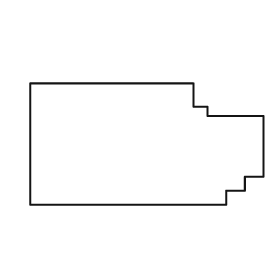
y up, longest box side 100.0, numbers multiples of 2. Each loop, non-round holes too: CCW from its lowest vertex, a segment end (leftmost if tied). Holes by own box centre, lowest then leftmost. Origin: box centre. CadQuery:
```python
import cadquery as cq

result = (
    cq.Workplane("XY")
    .moveTo(-50.0, -26.0)
    .lineTo(34.0, -26.0)
    .lineTo(34.0, -20.0)
    .lineTo(42.0, -20.0)
    .lineTo(42.0, -14.0)
    .lineTo(50.0, -14.0)
    .lineTo(50.0, 12.0)
    .lineTo(26.0, 12.0)
    .lineTo(26.0, 16.0)
    .lineTo(20.0, 16.0)
    .lineTo(20.0, 26.0)
    .lineTo(-50.0, 26.0)
    .close()
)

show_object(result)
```